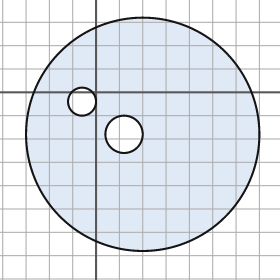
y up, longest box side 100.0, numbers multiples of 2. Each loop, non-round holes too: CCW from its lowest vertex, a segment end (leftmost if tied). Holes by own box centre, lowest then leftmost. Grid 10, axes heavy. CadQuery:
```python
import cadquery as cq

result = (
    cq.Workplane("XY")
    .moveTo(20.0, -18.0)
    .circle(50.0)
    .moveTo(12.0, -18.0)
    .circle(8.0)
    .moveTo(-6.0, -4.0)
    .circle(6.0)
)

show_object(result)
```